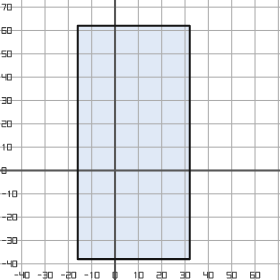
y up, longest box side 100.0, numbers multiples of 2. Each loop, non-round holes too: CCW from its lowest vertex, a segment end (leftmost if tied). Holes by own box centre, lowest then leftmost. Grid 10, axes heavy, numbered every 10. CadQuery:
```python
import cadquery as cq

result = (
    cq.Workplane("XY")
    .moveTo(-16.0, -38.0)
    .lineTo(32.0, -38.0)
    .lineTo(32.0, 62.0)
    .lineTo(-16.0, 62.0)
    .close()
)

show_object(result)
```